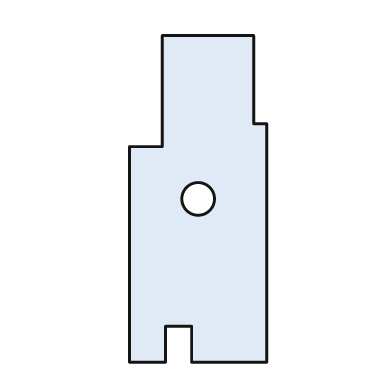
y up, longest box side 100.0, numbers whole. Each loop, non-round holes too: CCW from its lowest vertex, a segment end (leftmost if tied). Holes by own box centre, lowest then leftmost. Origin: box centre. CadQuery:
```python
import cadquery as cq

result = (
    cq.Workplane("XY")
    .moveTo(-21.0, -50.0)
    .lineTo(-10.0, -50.0)
    .lineTo(-10.0, -39.0)
    .lineTo(-2.0, -39.0)
    .lineTo(-2.0, -50.0)
    .lineTo(21.0, -50.0)
    .lineTo(21.0, 23.0)
    .lineTo(17.0, 23.0)
    .lineTo(17.0, 50.0)
    .lineTo(-11.0, 50.0)
    .lineTo(-11.0, 16.0)
    .lineTo(-21.0, 16.0)
    .close()
    .moveTo(0.0, 0.0)
    .circle(5.0)
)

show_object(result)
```